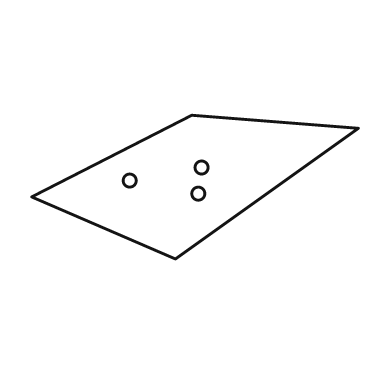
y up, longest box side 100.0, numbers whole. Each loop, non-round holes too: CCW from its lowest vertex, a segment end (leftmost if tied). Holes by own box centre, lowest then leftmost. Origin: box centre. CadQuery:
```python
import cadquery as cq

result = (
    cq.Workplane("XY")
    .moveTo(-6.0, -22.0)
    .lineTo(50.0, 18.0)
    .lineTo(-1.0, 22.0)
    .lineTo(-50.0, -3.0)
    .close()
    .moveTo(1.0, -2.0)
    .circle(2.0)
    .moveTo(-20.0, 2.0)
    .circle(2.0)
    .moveTo(2.0, 6.0)
    .circle(2.0)
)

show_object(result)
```